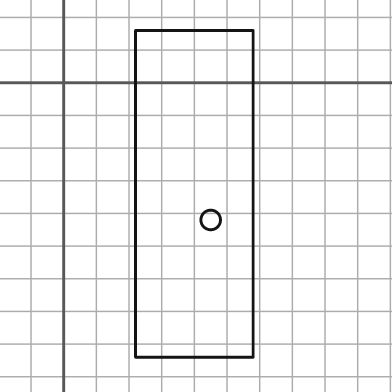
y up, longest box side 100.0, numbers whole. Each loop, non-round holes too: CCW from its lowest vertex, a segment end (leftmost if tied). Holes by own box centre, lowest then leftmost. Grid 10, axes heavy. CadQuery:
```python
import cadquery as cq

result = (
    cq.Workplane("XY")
    .moveTo(22.0, -84.0)
    .lineTo(58.0, -84.0)
    .lineTo(58.0, 16.0)
    .lineTo(22.0, 16.0)
    .close()
    .moveTo(45.0, -42.0)
    .circle(3.0)
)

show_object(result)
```